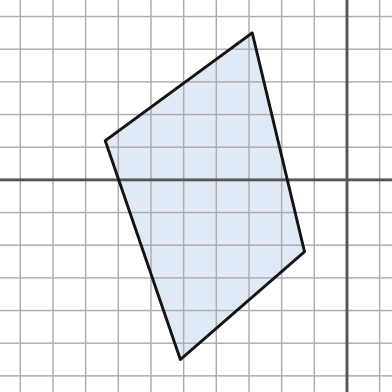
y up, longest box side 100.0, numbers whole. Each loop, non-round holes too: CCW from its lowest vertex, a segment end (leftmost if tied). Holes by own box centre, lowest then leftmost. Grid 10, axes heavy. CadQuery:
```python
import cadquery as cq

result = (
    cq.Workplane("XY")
    .moveTo(-51.0, -55.0)
    .lineTo(-13.0, -22.0)
    .lineTo(-29.0, 45.0)
    .lineTo(-74.0, 12.0)
    .close()
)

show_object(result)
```